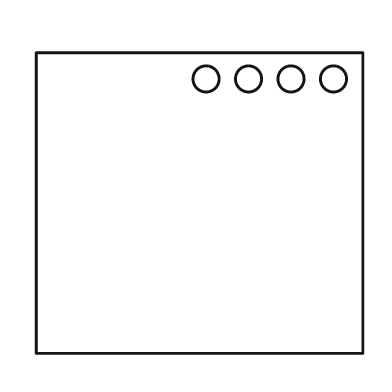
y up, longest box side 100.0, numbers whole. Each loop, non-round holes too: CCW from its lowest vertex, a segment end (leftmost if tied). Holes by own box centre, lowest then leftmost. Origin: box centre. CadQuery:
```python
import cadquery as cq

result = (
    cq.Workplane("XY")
    .moveTo(-50.0, -46.0)
    .lineTo(50.0, -46.0)
    .lineTo(50.0, 46.0)
    .lineTo(-50.0, 46.0)
    .close()
    .moveTo(2.0, 38.0)
    .circle(4.0)
    .moveTo(15.0, 38.0)
    .circle(4.0)
    .moveTo(28.0, 38.0)
    .circle(4.0)
    .moveTo(41.0, 38.0)
    .circle(4.0)
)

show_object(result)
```